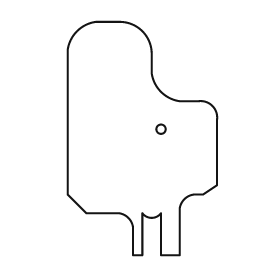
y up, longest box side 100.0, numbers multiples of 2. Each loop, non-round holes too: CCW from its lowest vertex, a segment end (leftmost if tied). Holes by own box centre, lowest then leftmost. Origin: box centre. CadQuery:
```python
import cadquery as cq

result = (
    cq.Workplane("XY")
    .moveTo(-4.0, -50.0)
    .lineTo(0.0, -50.0)
    .lineTo(0.0, -32.0)
    .threePointArc((4.0, -34.0), (8.0, -32.0))
    .lineTo(8.0, -50.0)
    .lineTo(16.0, -50.0)
    .lineTo(16.0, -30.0)
    .threePointArc((18.0, -26.0), (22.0, -24.0))
    .lineTo(26.0, -24.0)
    .lineTo(32.0, -20.0)
    .lineTo(32.0, 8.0)
    .threePointArc((30.0, 14.0), (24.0, 16.0))
    .lineTo(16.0, 16.0)
    .threePointArc((8.0, 20.0), (4.0, 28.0))
    .lineTo(4.0, 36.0)
    .threePointArc((0.0, 46.0), (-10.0, 50.0))
    .lineTo(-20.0, 50.0)
    .threePointArc((-28.0, 46.0), (-32.0, 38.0))
    .lineTo(-32.0, -24.0)
    .lineTo(-24.0, -32.0)
    .lineTo(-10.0, -32.0)
    .threePointArc((-6.0, -34.0), (-4.0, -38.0))
    .close()
    .moveTo(8.0, 4.0)
    .circle(2.0)
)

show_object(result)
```